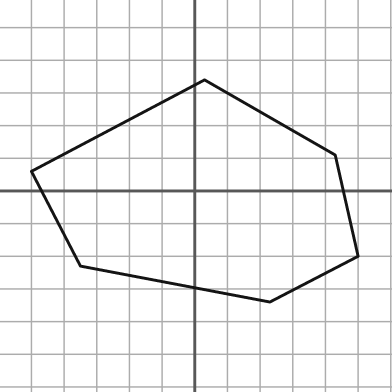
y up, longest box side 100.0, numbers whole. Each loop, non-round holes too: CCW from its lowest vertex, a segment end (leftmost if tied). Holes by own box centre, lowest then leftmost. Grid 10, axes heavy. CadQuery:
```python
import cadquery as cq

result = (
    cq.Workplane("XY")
    .moveTo(23.0, -34.0)
    .lineTo(50.0, -20.0)
    .lineTo(43.0, 11.0)
    .lineTo(3.0, 34.0)
    .lineTo(-50.0, 6.0)
    .lineTo(-35.0, -23.0)
    .close()
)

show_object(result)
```